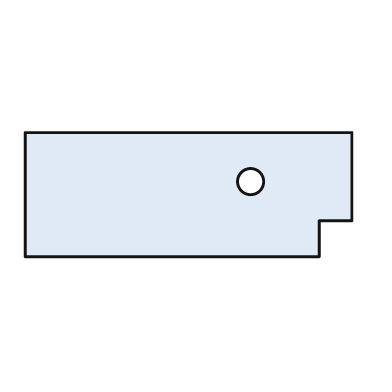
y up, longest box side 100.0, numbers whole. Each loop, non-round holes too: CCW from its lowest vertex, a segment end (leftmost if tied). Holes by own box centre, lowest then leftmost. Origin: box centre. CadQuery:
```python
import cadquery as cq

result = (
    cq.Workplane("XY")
    .moveTo(-50.0, -19.0)
    .lineTo(40.0, -19.0)
    .lineTo(40.0, -8.0)
    .lineTo(50.0, -8.0)
    .lineTo(50.0, 19.0)
    .lineTo(-50.0, 19.0)
    .close()
    .moveTo(19.0, 4.0)
    .circle(4.0)
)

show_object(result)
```